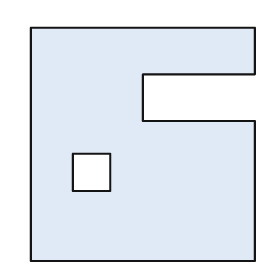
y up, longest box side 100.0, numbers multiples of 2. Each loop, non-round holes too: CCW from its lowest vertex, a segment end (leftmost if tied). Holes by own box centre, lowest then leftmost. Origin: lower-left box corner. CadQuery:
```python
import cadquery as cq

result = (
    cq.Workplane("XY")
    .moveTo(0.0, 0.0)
    .lineTo(96.0, 0.0)
    .lineTo(96.0, 60.0)
    .lineTo(48.0, 60.0)
    .lineTo(48.0, 80.0)
    .lineTo(96.0, 80.0)
    .lineTo(96.0, 100.0)
    .lineTo(0.0, 100.0)
    .close()
    .moveTo(18.0, 30.0)
    .lineTo(34.0, 30.0)
    .lineTo(34.0, 46.0)
    .lineTo(18.0, 46.0)
    .close()
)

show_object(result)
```